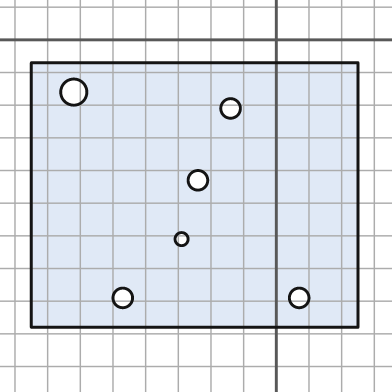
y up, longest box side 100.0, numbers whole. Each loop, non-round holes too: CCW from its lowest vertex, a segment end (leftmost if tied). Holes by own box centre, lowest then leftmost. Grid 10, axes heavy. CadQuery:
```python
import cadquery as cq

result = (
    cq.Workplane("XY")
    .moveTo(-75.0, -88.0)
    .lineTo(25.0, -88.0)
    .lineTo(25.0, -7.0)
    .lineTo(-75.0, -7.0)
    .close()
    .moveTo(-47.0, -79.0)
    .circle(3.0)
    .moveTo(7.0, -79.0)
    .circle(3.0)
    .moveTo(-29.0, -61.0)
    .circle(2.0)
    .moveTo(-24.0, -43.0)
    .circle(3.0)
    .moveTo(-14.0, -21.0)
    .circle(3.0)
    .moveTo(-62.0, -16.0)
    .circle(4.0)
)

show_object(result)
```